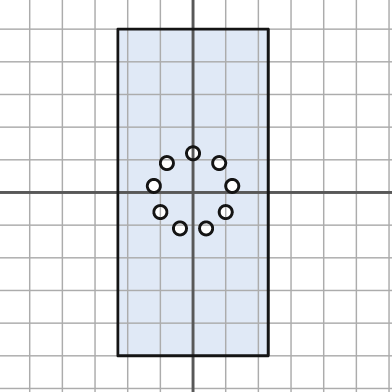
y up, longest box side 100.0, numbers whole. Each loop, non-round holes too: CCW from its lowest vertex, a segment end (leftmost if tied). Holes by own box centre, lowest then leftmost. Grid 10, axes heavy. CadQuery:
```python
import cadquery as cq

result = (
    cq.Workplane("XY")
    .moveTo(-23.0, -50.0)
    .lineTo(23.0, -50.0)
    .lineTo(23.0, 50.0)
    .lineTo(-23.0, 50.0)
    .close()
    .moveTo(-4.0, -11.0)
    .circle(2.0)
    .moveTo(4.0, -11.0)
    .circle(2.0)
    .moveTo(-10.0, -6.0)
    .circle(2.0)
    .moveTo(10.0, -6.0)
    .circle(2.0)
    .moveTo(-12.0, 2.0)
    .circle(2.0)
    .moveTo(12.0, 2.0)
    .circle(2.0)
    .moveTo(-8.0, 9.0)
    .circle(2.0)
    .moveTo(8.0, 9.0)
    .circle(2.0)
    .moveTo(0.0, 12.0)
    .circle(2.0)
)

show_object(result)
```